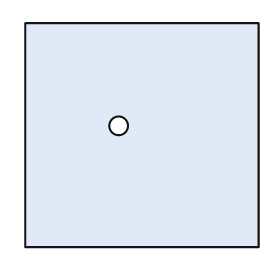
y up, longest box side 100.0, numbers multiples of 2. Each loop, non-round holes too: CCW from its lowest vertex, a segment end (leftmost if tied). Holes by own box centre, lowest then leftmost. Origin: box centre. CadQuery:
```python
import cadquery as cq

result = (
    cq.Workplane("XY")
    .moveTo(-50.0, -48.0)
    .lineTo(50.0, -48.0)
    .lineTo(50.0, 48.0)
    .lineTo(-50.0, 48.0)
    .close()
    .moveTo(-10.0, 4.0)
    .circle(4.0)
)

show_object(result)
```